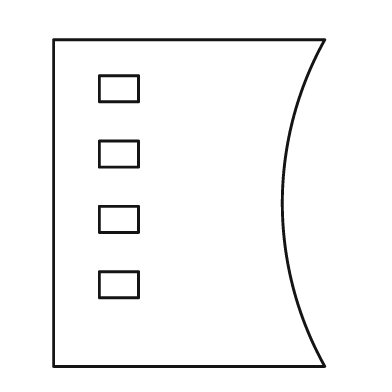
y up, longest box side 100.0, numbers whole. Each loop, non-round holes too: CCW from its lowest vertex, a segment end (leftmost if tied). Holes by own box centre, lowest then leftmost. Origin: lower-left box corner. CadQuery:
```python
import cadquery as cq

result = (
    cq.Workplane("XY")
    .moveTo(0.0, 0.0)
    .lineTo(83.0, 0.0)
    .threePointArc((70.0, 50.0), (83.0, 100.0))
    .lineTo(0.0, 100.0)
    .close()
    .moveTo(14.0, 21.0)
    .lineTo(26.0, 21.0)
    .lineTo(26.0, 29.0)
    .lineTo(14.0, 29.0)
    .close()
    .moveTo(14.0, 41.0)
    .lineTo(26.0, 41.0)
    .lineTo(26.0, 49.0)
    .lineTo(14.0, 49.0)
    .close()
    .moveTo(14.0, 61.0)
    .lineTo(26.0, 61.0)
    .lineTo(26.0, 69.0)
    .lineTo(14.0, 69.0)
    .close()
    .moveTo(14.0, 81.0)
    .lineTo(26.0, 81.0)
    .lineTo(26.0, 89.0)
    .lineTo(14.0, 89.0)
    .close()
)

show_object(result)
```